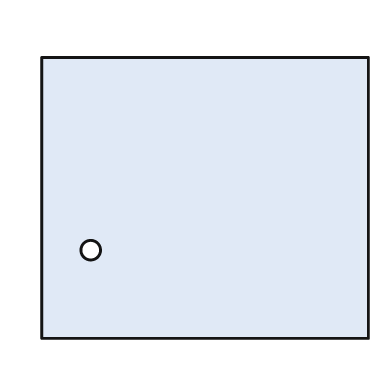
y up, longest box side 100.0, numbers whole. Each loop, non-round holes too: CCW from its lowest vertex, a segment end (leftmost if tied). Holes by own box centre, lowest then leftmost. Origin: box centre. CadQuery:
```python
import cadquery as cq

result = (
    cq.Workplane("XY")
    .moveTo(-50.0, -43.0)
    .lineTo(50.0, -43.0)
    .lineTo(50.0, 43.0)
    .lineTo(-50.0, 43.0)
    .close()
    .moveTo(-35.0, -16.0)
    .circle(3.0)
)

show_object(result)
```